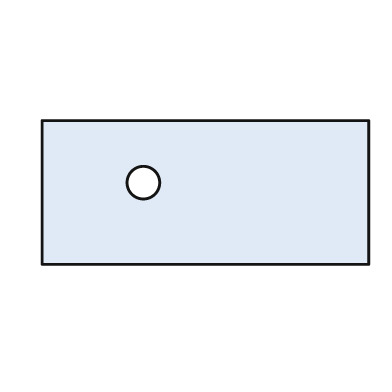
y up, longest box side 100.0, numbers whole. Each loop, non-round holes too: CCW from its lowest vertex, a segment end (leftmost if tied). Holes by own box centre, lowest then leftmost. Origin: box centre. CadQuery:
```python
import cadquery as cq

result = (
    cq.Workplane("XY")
    .moveTo(-50.0, -22.0)
    .lineTo(50.0, -22.0)
    .lineTo(50.0, 22.0)
    .lineTo(-50.0, 22.0)
    .close()
    .moveTo(-19.0, 3.0)
    .circle(5.0)
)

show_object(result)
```